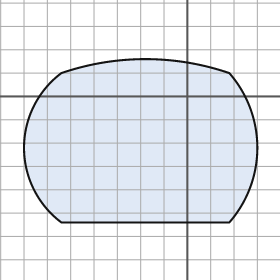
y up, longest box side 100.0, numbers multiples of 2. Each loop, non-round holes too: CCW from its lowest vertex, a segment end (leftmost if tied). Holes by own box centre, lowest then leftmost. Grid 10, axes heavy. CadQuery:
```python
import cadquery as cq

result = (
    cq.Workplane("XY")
    .moveTo(-54.0, -54.0)
    .lineTo(18.0, -54.0)
    .threePointArc((30.0, -22.0), (18.0, 10.0))
    .threePointArc((-18.0, 16.0), (-54.0, 10.0))
    .threePointArc((-70.0, -22.0), (-54.0, -54.0))
    .close()
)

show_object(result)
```